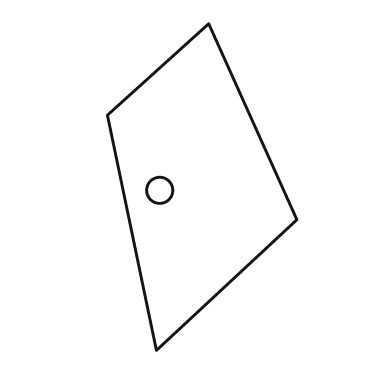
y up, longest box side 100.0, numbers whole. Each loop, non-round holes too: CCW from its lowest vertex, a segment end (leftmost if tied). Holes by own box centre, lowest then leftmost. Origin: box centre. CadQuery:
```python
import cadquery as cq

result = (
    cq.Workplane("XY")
    .moveTo(-14.0, -50.0)
    .lineTo(29.0, -10.0)
    .lineTo(2.0, 50.0)
    .lineTo(-29.0, 22.0)
    .close()
    .moveTo(-13.0, -1.0)
    .circle(4.0)
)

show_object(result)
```